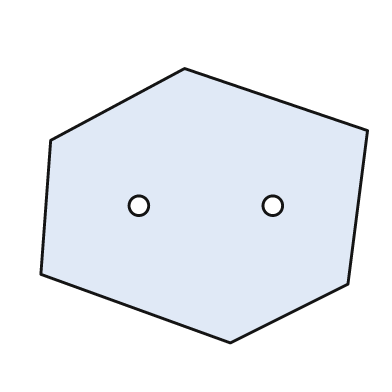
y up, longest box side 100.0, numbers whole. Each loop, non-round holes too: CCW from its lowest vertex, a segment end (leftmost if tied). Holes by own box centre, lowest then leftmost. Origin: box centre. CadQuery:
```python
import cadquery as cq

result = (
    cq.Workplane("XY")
    .moveTo(8.0, -42.0)
    .lineTo(44.0, -24.0)
    .lineTo(50.0, 23.0)
    .lineTo(-6.0, 42.0)
    .lineTo(-47.0, 20.0)
    .lineTo(-50.0, -21.0)
    .close()
    .moveTo(-20.0, 0.0)
    .circle(3.0)
    .moveTo(21.0, 0.0)
    .circle(3.0)
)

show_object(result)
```